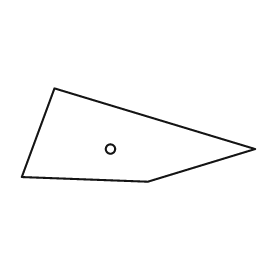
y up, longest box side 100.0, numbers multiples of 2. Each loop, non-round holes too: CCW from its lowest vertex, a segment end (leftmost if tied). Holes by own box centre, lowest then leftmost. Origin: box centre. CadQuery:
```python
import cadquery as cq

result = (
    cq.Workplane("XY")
    .moveTo(4.0, -20.0)
    .lineTo(50.0, -6.0)
    .lineTo(-36.0, 20.0)
    .lineTo(-50.0, -18.0)
    .close()
    .moveTo(-12.0, -6.0)
    .circle(2.0)
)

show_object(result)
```